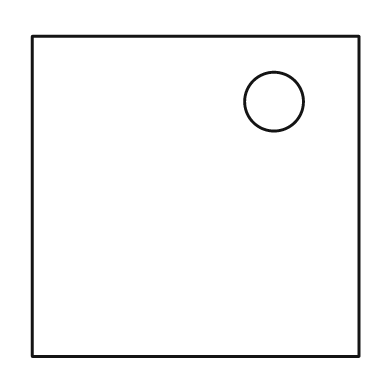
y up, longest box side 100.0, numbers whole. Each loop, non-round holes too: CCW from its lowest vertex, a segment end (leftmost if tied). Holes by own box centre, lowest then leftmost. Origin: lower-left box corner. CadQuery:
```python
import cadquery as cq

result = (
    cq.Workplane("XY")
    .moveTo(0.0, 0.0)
    .lineTo(100.0, 0.0)
    .lineTo(100.0, 98.0)
    .lineTo(0.0, 98.0)
    .close()
    .moveTo(74.0, 78.0)
    .circle(9.0)
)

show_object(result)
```